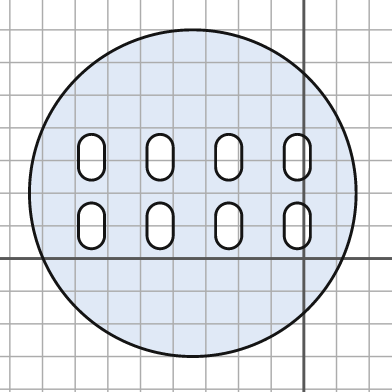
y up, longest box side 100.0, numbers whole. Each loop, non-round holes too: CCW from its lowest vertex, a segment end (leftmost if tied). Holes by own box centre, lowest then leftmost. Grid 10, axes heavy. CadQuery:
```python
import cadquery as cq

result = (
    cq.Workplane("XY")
    .moveTo(-34.0, 20.0)
    .circle(50.0)
    .moveTo(-69.0, 7.0)
    .threePointArc((-65.0, 3.0), (-61.0, 7.0))
    .lineTo(-61.0, 13.0)
    .threePointArc((-65.0, 17.0), (-69.0, 13.0))
    .close()
    .moveTo(-48.0, 7.0)
    .threePointArc((-44.0, 3.0), (-40.0, 7.0))
    .lineTo(-40.0, 13.0)
    .threePointArc((-44.0, 17.0), (-48.0, 13.0))
    .close()
    .moveTo(-27.0, 7.0)
    .threePointArc((-23.0, 3.0), (-19.0, 7.0))
    .lineTo(-19.0, 13.0)
    .threePointArc((-23.0, 17.0), (-27.0, 13.0))
    .close()
    .moveTo(-6.0, 7.0)
    .threePointArc((-2.0, 3.0), (2.0, 7.0))
    .lineTo(2.0, 13.0)
    .threePointArc((-2.0, 17.0), (-6.0, 13.0))
    .close()
    .moveTo(-69.0, 28.0)
    .threePointArc((-65.0, 24.0), (-61.0, 28.0))
    .lineTo(-61.0, 34.0)
    .threePointArc((-65.0, 38.0), (-69.0, 34.0))
    .close()
    .moveTo(-48.0, 28.0)
    .threePointArc((-44.0, 24.0), (-40.0, 28.0))
    .lineTo(-40.0, 34.0)
    .threePointArc((-44.0, 38.0), (-48.0, 34.0))
    .close()
    .moveTo(-27.0, 28.0)
    .threePointArc((-23.0, 24.0), (-19.0, 28.0))
    .lineTo(-19.0, 34.0)
    .threePointArc((-23.0, 38.0), (-27.0, 34.0))
    .close()
    .moveTo(-6.0, 28.0)
    .threePointArc((-2.0, 24.0), (2.0, 28.0))
    .lineTo(2.0, 34.0)
    .threePointArc((-2.0, 38.0), (-6.0, 34.0))
    .close()
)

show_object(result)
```